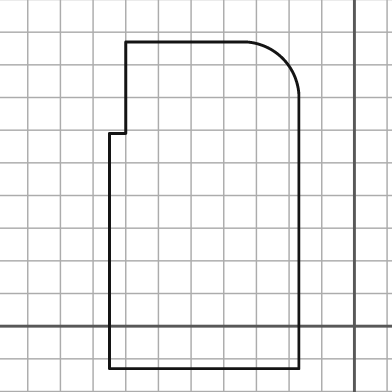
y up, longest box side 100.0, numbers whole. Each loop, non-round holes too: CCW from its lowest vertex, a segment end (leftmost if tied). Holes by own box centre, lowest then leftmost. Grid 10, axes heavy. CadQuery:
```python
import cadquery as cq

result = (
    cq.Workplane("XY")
    .moveTo(-75.0, -13.0)
    .lineTo(-17.0, -13.0)
    .lineTo(-17.0, 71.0)
    .threePointArc((-22.0, 82.0), (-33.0, 87.0))
    .lineTo(-70.0, 87.0)
    .lineTo(-70.0, 59.0)
    .lineTo(-75.0, 59.0)
    .close()
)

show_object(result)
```